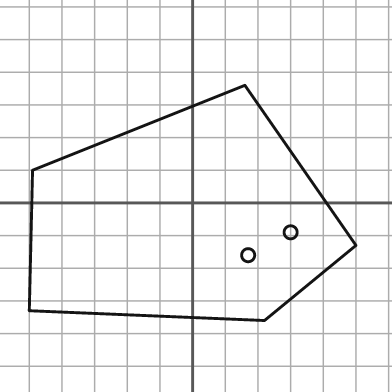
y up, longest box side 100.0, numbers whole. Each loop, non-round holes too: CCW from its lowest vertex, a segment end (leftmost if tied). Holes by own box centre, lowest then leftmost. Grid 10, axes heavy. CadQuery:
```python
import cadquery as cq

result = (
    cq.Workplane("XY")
    .moveTo(22.0, -36.0)
    .lineTo(50.0, -13.0)
    .lineTo(16.0, 36.0)
    .lineTo(-49.0, 10.0)
    .lineTo(-50.0, -33.0)
    .close()
    .moveTo(17.0, -16.0)
    .circle(2.0)
    .moveTo(30.0, -9.0)
    .circle(2.0)
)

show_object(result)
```